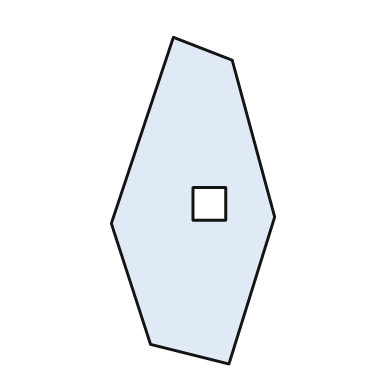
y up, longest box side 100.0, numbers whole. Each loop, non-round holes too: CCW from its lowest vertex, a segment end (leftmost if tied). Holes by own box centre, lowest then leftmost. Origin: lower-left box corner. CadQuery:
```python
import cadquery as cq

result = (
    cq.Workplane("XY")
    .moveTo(36.0, 0.0)
    .lineTo(50.0, 45.0)
    .lineTo(37.0, 93.0)
    .lineTo(19.0, 100.0)
    .lineTo(0.0, 43.0)
    .lineTo(12.0, 6.0)
    .close()
    .moveTo(25.0, 44.0)
    .lineTo(35.0, 44.0)
    .lineTo(35.0, 54.0)
    .lineTo(25.0, 54.0)
    .close()
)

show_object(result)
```